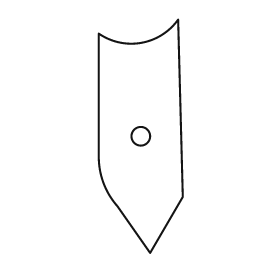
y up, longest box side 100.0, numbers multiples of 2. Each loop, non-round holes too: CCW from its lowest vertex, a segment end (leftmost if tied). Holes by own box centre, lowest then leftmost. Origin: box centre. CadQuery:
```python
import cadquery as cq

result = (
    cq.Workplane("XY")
    .moveTo(4.0, -50.0)
    .lineTo(18.0, -26.0)
    .lineTo(16.0, 50.0)
    .threePointArc((0.0, 40.0), (-18.0, 44.0))
    .lineTo(-18.0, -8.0)
    .threePointArc((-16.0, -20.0), (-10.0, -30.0))
    .close()
    .moveTo(0.0, 0.0)
    .circle(4.0)
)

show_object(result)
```